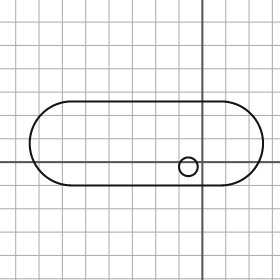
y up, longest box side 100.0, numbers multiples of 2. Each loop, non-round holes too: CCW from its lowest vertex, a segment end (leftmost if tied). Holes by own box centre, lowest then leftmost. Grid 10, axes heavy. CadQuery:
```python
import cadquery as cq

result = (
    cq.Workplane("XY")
    .moveTo(-56.0, -10.0)
    .lineTo(8.0, -10.0)
    .threePointArc((26.0, 8.0), (8.0, 26.0))
    .lineTo(-56.0, 26.0)
    .threePointArc((-74.0, 8.0), (-56.0, -10.0))
    .close()
    .moveTo(-6.0, -2.0)
    .circle(4.0)
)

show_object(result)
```